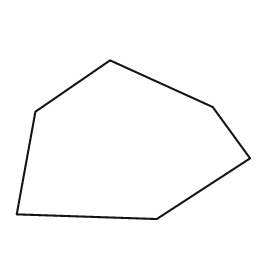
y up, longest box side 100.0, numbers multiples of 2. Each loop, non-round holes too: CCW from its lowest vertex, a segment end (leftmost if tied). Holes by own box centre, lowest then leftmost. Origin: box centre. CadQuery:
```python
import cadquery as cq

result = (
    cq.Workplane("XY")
    .moveTo(10.0, -34.0)
    .lineTo(50.0, -8.0)
    .lineTo(34.0, 14.0)
    .lineTo(-10.0, 34.0)
    .lineTo(-42.0, 12.0)
    .lineTo(-50.0, -32.0)
    .close()
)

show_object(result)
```